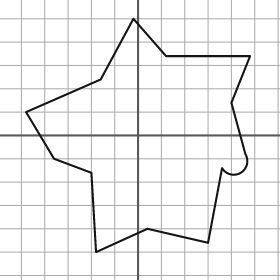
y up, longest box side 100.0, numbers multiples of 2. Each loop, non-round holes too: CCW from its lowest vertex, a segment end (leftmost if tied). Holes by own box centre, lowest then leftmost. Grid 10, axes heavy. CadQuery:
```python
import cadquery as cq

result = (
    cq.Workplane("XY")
    .moveTo(-18.0, -50.0)
    .lineTo(4.0, -40.0)
    .lineTo(30.0, -46.0)
    .lineTo(36.0, -14.0)
    .threePointArc((44.0, -16.0), (46.0, -8.0))
    .lineTo(40.0, 14.0)
    .lineTo(48.0, 34.0)
    .lineTo(12.0, 34.0)
    .lineTo(-2.0, 50.0)
    .lineTo(-16.0, 24.0)
    .lineTo(-48.0, 10.0)
    .lineTo(-36.0, -10.0)
    .lineTo(-20.0, -16.0)
    .close()
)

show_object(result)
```